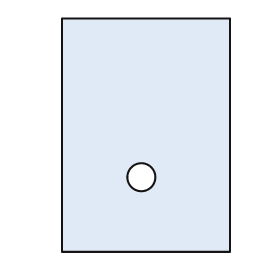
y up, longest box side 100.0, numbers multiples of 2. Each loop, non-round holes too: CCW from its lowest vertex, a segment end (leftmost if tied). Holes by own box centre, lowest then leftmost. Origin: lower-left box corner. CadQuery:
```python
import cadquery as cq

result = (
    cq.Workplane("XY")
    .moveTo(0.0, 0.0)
    .lineTo(72.0, 0.0)
    .lineTo(72.0, 100.0)
    .lineTo(0.0, 100.0)
    .close()
    .moveTo(34.0, 32.0)
    .circle(6.0)
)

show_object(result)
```